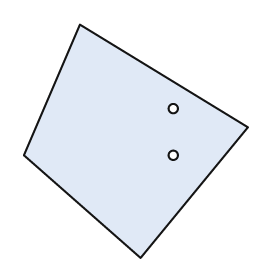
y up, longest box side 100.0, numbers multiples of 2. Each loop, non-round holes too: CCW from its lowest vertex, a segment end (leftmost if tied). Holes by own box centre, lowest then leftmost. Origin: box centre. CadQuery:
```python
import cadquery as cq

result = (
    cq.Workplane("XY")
    .moveTo(2.0, -50.0)
    .lineTo(48.0, 6.0)
    .lineTo(-24.0, 50.0)
    .lineTo(-48.0, -6.0)
    .close()
    .moveTo(16.0, -6.0)
    .circle(2.0)
    .moveTo(16.0, 14.0)
    .circle(2.0)
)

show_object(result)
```